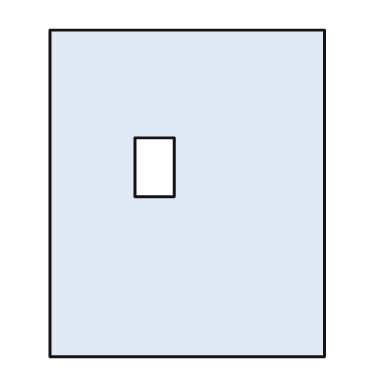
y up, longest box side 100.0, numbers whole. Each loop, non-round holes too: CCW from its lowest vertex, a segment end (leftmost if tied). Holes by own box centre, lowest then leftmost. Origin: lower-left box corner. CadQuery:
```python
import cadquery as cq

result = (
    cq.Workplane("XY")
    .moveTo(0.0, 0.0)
    .lineTo(84.0, 0.0)
    .lineTo(84.0, 100.0)
    .lineTo(0.0, 100.0)
    .close()
    .moveTo(26.0, 49.0)
    .lineTo(38.0, 49.0)
    .lineTo(38.0, 67.0)
    .lineTo(26.0, 67.0)
    .close()
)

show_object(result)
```